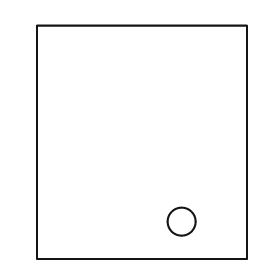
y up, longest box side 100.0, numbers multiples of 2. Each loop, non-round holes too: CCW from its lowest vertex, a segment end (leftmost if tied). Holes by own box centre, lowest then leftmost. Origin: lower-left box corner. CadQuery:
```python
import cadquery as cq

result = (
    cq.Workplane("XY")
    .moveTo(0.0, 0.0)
    .lineTo(90.0, 0.0)
    .lineTo(90.0, 100.0)
    .lineTo(0.0, 100.0)
    .close()
    .moveTo(62.0, 16.0)
    .circle(6.0)
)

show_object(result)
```